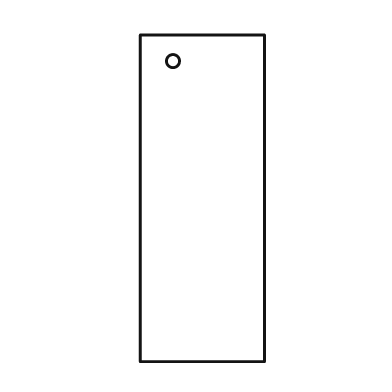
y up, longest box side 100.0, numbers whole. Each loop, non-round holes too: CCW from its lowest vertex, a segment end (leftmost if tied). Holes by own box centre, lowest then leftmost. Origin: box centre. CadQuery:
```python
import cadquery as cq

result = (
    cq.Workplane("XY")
    .moveTo(-19.0, -50.0)
    .lineTo(19.0, -50.0)
    .lineTo(19.0, 50.0)
    .lineTo(-19.0, 50.0)
    .close()
    .moveTo(-9.0, 42.0)
    .circle(2.0)
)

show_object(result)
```